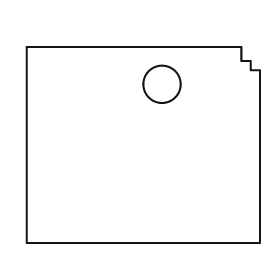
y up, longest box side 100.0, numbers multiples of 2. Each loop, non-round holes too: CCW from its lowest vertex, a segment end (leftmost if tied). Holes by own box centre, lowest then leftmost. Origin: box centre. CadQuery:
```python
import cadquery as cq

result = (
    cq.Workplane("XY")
    .moveTo(-50.0, -42.0)
    .lineTo(50.0, -42.0)
    .lineTo(50.0, 32.0)
    .lineTo(46.0, 32.0)
    .lineTo(46.0, 36.0)
    .lineTo(42.0, 36.0)
    .lineTo(42.0, 42.0)
    .lineTo(-50.0, 42.0)
    .close()
    .moveTo(8.0, 26.0)
    .circle(8.0)
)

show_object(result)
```